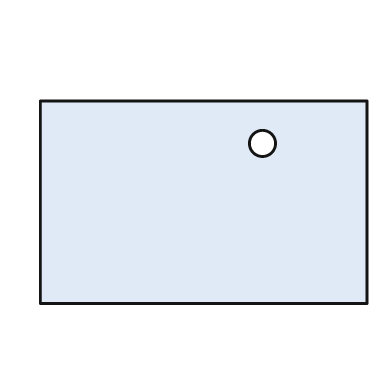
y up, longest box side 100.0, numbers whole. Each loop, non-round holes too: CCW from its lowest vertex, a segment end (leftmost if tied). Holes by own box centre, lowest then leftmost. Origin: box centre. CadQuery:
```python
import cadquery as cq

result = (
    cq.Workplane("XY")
    .moveTo(-50.0, -31.0)
    .lineTo(50.0, -31.0)
    .lineTo(50.0, 31.0)
    .lineTo(-50.0, 31.0)
    .close()
    .moveTo(18.0, 18.0)
    .circle(4.0)
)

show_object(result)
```